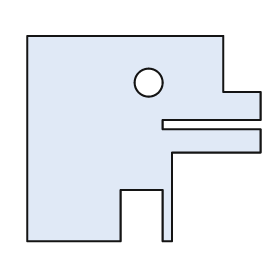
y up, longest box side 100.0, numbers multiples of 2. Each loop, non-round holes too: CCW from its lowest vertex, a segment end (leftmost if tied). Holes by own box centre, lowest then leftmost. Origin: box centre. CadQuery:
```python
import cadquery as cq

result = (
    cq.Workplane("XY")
    .moveTo(-50.0, -44.0)
    .lineTo(-10.0, -44.0)
    .lineTo(-10.0, -22.0)
    .lineTo(8.0, -22.0)
    .lineTo(8.0, -44.0)
    .lineTo(12.0, -44.0)
    .lineTo(12.0, -6.0)
    .lineTo(50.0, -6.0)
    .lineTo(50.0, 4.0)
    .lineTo(8.0, 4.0)
    .lineTo(8.0, 8.0)
    .lineTo(50.0, 8.0)
    .lineTo(50.0, 20.0)
    .lineTo(34.0, 20.0)
    .lineTo(34.0, 44.0)
    .lineTo(-50.0, 44.0)
    .close()
    .moveTo(2.0, 24.0)
    .circle(6.0)
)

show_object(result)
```